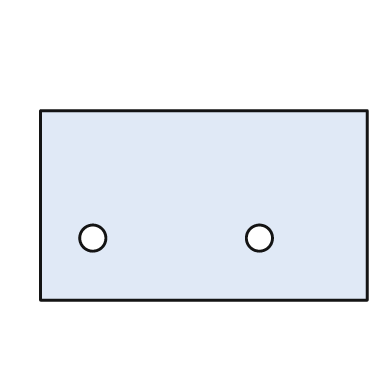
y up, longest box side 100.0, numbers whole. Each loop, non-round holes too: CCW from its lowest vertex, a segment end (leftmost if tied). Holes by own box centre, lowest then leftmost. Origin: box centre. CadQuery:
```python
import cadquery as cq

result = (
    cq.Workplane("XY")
    .moveTo(-50.0, -29.0)
    .lineTo(50.0, -29.0)
    .lineTo(50.0, 29.0)
    .lineTo(-50.0, 29.0)
    .close()
    .moveTo(-34.0, -10.0)
    .circle(4.0)
    .moveTo(17.0, -10.0)
    .circle(4.0)
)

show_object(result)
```